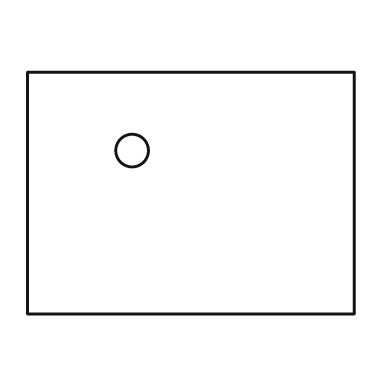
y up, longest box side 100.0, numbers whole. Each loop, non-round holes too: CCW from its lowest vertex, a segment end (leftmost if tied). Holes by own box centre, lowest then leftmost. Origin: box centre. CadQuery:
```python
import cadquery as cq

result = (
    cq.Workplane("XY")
    .moveTo(-50.0, -37.0)
    .lineTo(50.0, -37.0)
    .lineTo(50.0, 37.0)
    .lineTo(-50.0, 37.0)
    .close()
    .moveTo(-18.0, 13.0)
    .circle(5.0)
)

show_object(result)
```